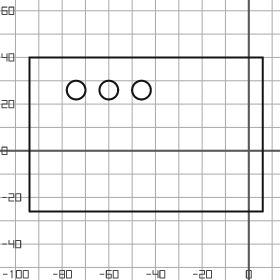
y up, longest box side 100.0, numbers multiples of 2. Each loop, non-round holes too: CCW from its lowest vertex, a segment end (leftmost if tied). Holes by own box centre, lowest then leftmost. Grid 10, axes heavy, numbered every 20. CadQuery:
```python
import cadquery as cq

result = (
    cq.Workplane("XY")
    .moveTo(-94.0, -26.0)
    .lineTo(6.0, -26.0)
    .lineTo(6.0, 40.0)
    .lineTo(-94.0, 40.0)
    .close()
    .moveTo(-74.0, 26.0)
    .circle(4.0)
    .moveTo(-60.0, 26.0)
    .circle(4.0)
    .moveTo(-46.0, 26.0)
    .circle(4.0)
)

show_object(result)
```